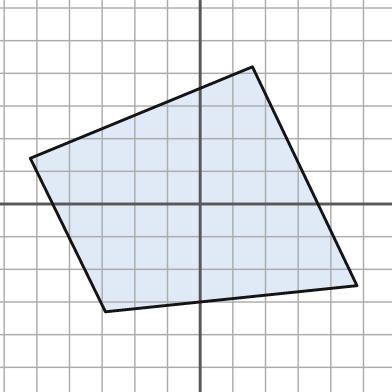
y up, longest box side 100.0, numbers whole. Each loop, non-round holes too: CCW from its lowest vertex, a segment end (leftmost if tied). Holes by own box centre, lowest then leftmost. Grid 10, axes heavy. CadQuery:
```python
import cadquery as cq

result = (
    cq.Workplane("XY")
    .moveTo(-29.0, -33.0)
    .lineTo(48.0, -25.0)
    .lineTo(16.0, 42.0)
    .lineTo(-52.0, 14.0)
    .close()
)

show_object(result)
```